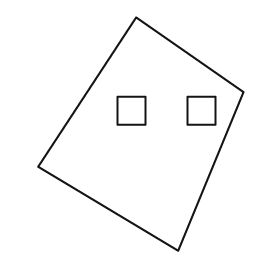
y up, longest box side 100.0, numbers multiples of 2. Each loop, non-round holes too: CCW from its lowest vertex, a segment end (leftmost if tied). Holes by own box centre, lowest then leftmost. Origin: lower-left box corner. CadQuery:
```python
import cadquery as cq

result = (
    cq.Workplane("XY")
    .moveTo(60.0, 0.0)
    .lineTo(88.0, 68.0)
    .lineTo(42.0, 100.0)
    .lineTo(0.0, 36.0)
    .close()
    .moveTo(34.0, 54.0)
    .lineTo(46.0, 54.0)
    .lineTo(46.0, 66.0)
    .lineTo(34.0, 66.0)
    .close()
    .moveTo(64.0, 54.0)
    .lineTo(76.0, 54.0)
    .lineTo(76.0, 66.0)
    .lineTo(64.0, 66.0)
    .close()
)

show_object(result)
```